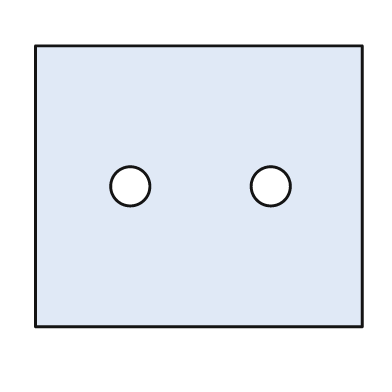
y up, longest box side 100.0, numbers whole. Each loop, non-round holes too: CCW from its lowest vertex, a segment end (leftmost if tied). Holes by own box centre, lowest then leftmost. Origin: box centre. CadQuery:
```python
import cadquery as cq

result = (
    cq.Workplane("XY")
    .moveTo(-50.0, -43.0)
    .lineTo(50.0, -43.0)
    .lineTo(50.0, 43.0)
    .lineTo(-50.0, 43.0)
    .close()
    .moveTo(-21.0, 0.0)
    .circle(6.0)
    .moveTo(22.0, 0.0)
    .circle(6.0)
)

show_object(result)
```